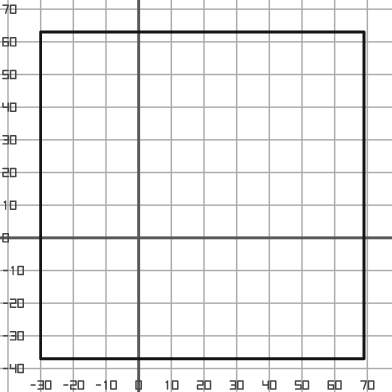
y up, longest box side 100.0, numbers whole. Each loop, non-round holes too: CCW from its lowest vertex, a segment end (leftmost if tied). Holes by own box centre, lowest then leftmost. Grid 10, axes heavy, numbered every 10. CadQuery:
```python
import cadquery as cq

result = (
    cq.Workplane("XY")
    .moveTo(-30.0, -37.0)
    .lineTo(69.0, -37.0)
    .lineTo(69.0, 63.0)
    .lineTo(-30.0, 63.0)
    .close()
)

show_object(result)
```